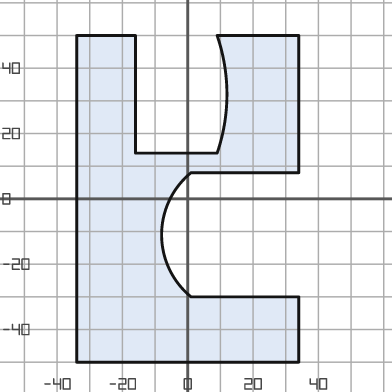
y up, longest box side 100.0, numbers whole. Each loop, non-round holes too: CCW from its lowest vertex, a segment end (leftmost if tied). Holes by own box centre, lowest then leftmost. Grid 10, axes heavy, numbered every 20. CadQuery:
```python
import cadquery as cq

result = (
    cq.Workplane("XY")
    .moveTo(-34.0, -50.0)
    .lineTo(34.0, -50.0)
    .lineTo(34.0, -30.0)
    .lineTo(1.0, -30.0)
    .threePointArc((-8.0, -11.0), (1.0, 8.0))
    .lineTo(34.0, 8.0)
    .lineTo(34.0, 50.0)
    .lineTo(9.0, 50.0)
    .threePointArc((12.0, 32.0), (9.0, 14.0))
    .lineTo(-16.0, 14.0)
    .lineTo(-16.0, 50.0)
    .lineTo(-34.0, 50.0)
    .close()
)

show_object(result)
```